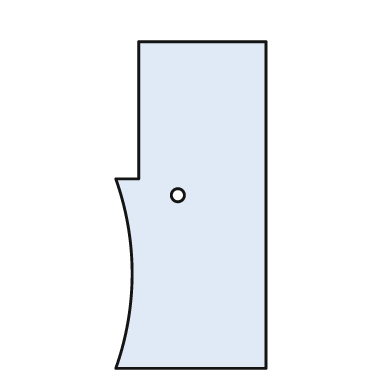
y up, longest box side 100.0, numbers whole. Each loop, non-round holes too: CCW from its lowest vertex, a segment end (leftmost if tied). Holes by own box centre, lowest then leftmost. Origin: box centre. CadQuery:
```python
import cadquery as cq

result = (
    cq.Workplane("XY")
    .moveTo(-23.0, -50.0)
    .lineTo(23.0, -50.0)
    .lineTo(23.0, 50.0)
    .lineTo(-16.0, 50.0)
    .lineTo(-16.0, 8.0)
    .lineTo(-23.0, 8.0)
    .threePointArc((-18.0, -21.0), (-23.0, -50.0))
    .close()
    .moveTo(-4.0, 3.0)
    .circle(2.0)
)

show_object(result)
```